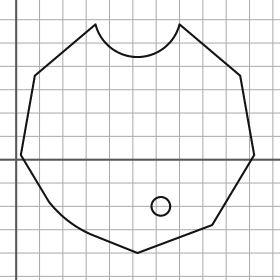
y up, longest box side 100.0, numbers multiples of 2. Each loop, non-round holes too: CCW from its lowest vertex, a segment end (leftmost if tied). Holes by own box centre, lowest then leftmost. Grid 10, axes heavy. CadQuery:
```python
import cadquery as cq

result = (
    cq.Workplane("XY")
    .moveTo(52.0, -40.0)
    .lineTo(84.0, -28.0)
    .lineTo(102.0, 2.0)
    .lineTo(96.0, 36.0)
    .lineTo(70.0, 58.0)
    .threePointArc((52.0, 44.0), (34.0, 58.0))
    .lineTo(8.0, 36.0)
    .lineTo(2.0, 2.0)
    .lineTo(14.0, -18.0)
    .threePointArc((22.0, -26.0), (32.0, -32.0))
    .close()
    .moveTo(62.0, -20.0)
    .circle(4.0)
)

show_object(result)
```